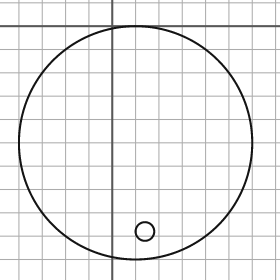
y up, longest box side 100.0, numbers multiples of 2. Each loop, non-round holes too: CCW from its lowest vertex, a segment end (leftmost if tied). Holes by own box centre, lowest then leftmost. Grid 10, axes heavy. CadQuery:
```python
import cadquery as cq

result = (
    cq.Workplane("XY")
    .moveTo(10.0, -50.0)
    .circle(50.0)
    .moveTo(14.0, -88.0)
    .circle(4.0)
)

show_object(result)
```